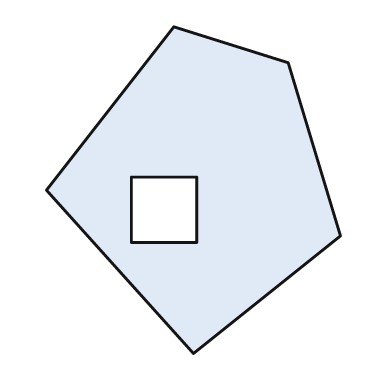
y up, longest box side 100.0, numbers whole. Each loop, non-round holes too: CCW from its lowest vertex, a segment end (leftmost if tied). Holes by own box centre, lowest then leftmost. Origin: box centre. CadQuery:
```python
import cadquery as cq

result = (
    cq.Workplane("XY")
    .moveTo(0.0, -50.0)
    .lineTo(45.0, -14.0)
    .lineTo(29.0, 39.0)
    .lineTo(-6.0, 50.0)
    .lineTo(-45.0, 0.0)
    .close()
    .moveTo(-19.0, -16.0)
    .lineTo(1.0, -16.0)
    .lineTo(1.0, 4.0)
    .lineTo(-19.0, 4.0)
    .close()
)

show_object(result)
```